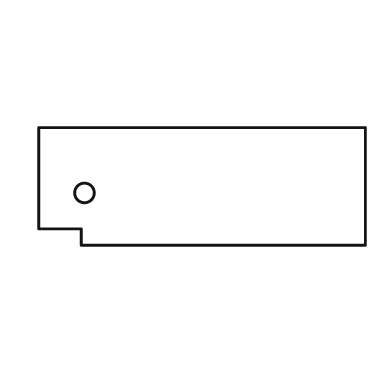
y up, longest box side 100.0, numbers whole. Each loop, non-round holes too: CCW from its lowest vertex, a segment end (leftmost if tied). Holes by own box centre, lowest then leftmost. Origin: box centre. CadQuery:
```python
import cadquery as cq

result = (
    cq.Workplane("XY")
    .moveTo(-37.0, -18.0)
    .lineTo(50.0, -18.0)
    .lineTo(50.0, 18.0)
    .lineTo(-50.0, 18.0)
    .lineTo(-50.0, -13.0)
    .lineTo(-37.0, -13.0)
    .close()
    .moveTo(-36.0, -2.0)
    .circle(3.0)
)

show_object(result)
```